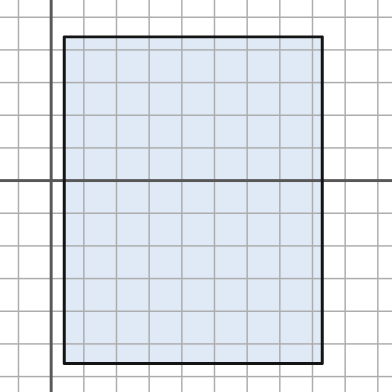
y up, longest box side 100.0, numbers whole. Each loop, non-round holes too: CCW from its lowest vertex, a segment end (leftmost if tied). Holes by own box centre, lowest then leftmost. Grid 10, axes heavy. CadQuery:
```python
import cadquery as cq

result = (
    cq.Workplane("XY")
    .moveTo(4.0, -56.0)
    .lineTo(83.0, -56.0)
    .lineTo(83.0, 44.0)
    .lineTo(4.0, 44.0)
    .close()
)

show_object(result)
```